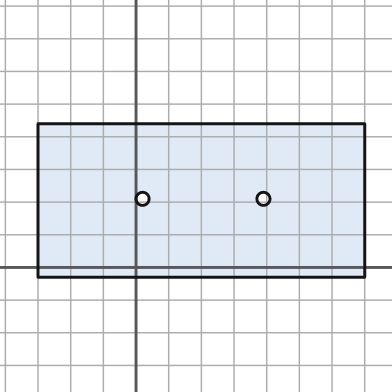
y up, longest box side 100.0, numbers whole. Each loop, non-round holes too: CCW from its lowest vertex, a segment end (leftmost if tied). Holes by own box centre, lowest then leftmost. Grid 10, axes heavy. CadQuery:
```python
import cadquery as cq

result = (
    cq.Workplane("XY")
    .moveTo(-30.0, -3.0)
    .lineTo(70.0, -3.0)
    .lineTo(70.0, 44.0)
    .lineTo(-30.0, 44.0)
    .close()
    .moveTo(2.0, 21.0)
    .circle(2.0)
    .moveTo(39.0, 21.0)
    .circle(2.0)
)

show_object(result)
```